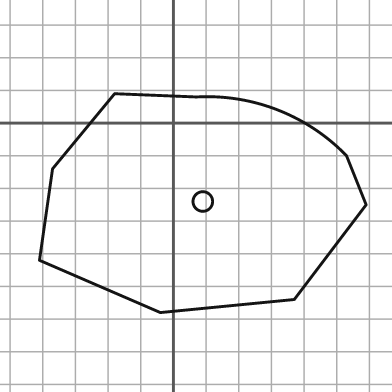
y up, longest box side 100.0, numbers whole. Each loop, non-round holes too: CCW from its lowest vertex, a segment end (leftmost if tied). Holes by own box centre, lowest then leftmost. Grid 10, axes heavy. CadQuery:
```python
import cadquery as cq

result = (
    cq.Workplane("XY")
    .moveTo(-4.0, -58.0)
    .lineTo(37.0, -54.0)
    .lineTo(59.0, -25.0)
    .lineTo(53.0, -10.0)
    .threePointArc((32.0, 4.0), (7.0, 8.0))
    .lineTo(-18.0, 9.0)
    .lineTo(-37.0, -14.0)
    .lineTo(-41.0, -42.0)
    .close()
    .moveTo(9.0, -24.0)
    .circle(3.0)
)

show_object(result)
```